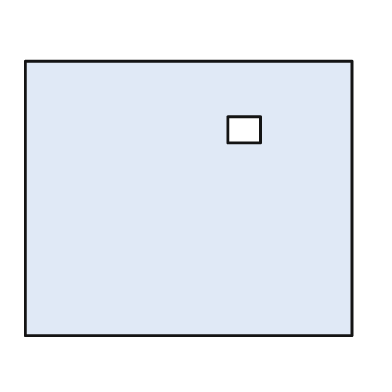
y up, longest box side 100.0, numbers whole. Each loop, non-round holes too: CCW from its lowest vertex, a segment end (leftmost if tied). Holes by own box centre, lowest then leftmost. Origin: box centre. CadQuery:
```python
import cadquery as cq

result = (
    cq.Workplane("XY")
    .moveTo(-50.0, -42.0)
    .lineTo(50.0, -42.0)
    .lineTo(50.0, 42.0)
    .lineTo(-50.0, 42.0)
    .close()
    .moveTo(12.0, 17.0)
    .lineTo(22.0, 17.0)
    .lineTo(22.0, 25.0)
    .lineTo(12.0, 25.0)
    .close()
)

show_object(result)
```